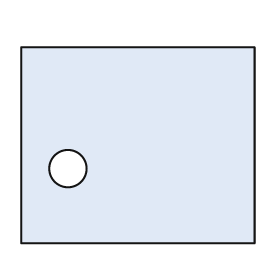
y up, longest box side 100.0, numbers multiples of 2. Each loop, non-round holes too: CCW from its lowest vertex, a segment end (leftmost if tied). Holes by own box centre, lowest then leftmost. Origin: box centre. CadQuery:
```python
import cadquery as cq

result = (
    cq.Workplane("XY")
    .moveTo(-50.0, -42.0)
    .lineTo(50.0, -42.0)
    .lineTo(50.0, 42.0)
    .lineTo(-50.0, 42.0)
    .close()
    .moveTo(-30.0, -10.0)
    .circle(8.0)
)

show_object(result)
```